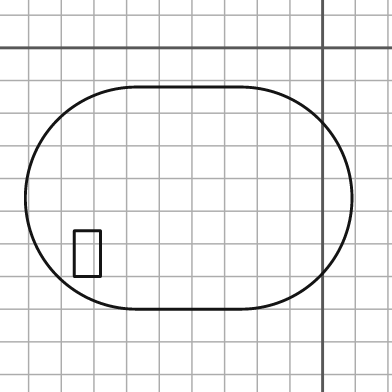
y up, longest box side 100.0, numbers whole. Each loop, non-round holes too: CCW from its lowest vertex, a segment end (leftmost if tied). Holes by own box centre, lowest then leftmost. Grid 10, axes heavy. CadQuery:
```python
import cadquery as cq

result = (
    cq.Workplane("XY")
    .moveTo(-57.0, -80.0)
    .lineTo(-25.0, -80.0)
    .threePointArc((9.0, -46.0), (-25.0, -12.0))
    .lineTo(-57.0, -12.0)
    .threePointArc((-91.0, -46.0), (-57.0, -80.0))
    .close()
    .moveTo(-76.0, -70.0)
    .lineTo(-68.0, -70.0)
    .lineTo(-68.0, -56.0)
    .lineTo(-76.0, -56.0)
    .close()
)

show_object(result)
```